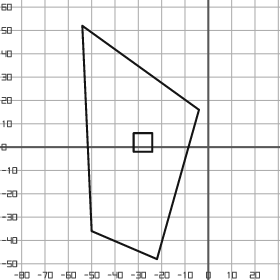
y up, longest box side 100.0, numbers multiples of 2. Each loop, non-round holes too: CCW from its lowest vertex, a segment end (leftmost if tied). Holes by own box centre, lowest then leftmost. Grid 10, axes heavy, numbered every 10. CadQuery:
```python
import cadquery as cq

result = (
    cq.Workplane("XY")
    .moveTo(-22.0, -48.0)
    .lineTo(-4.0, 16.0)
    .lineTo(-54.0, 52.0)
    .lineTo(-50.0, -36.0)
    .close()
    .moveTo(-32.0, -2.0)
    .lineTo(-24.0, -2.0)
    .lineTo(-24.0, 6.0)
    .lineTo(-32.0, 6.0)
    .close()
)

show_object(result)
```